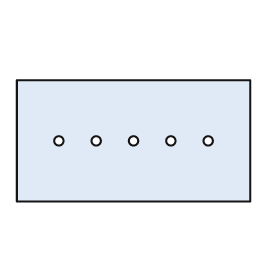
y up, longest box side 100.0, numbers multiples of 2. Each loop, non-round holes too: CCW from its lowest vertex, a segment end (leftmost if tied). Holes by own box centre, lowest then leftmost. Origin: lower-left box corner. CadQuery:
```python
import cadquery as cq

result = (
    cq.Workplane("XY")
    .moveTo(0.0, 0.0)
    .lineTo(100.0, 0.0)
    .lineTo(100.0, 52.0)
    .lineTo(0.0, 52.0)
    .close()
    .moveTo(18.0, 26.0)
    .circle(2.0)
    .moveTo(34.0, 26.0)
    .circle(2.0)
    .moveTo(50.0, 26.0)
    .circle(2.0)
    .moveTo(66.0, 26.0)
    .circle(2.0)
    .moveTo(82.0, 26.0)
    .circle(2.0)
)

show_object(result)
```